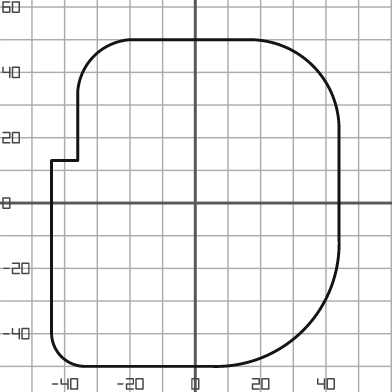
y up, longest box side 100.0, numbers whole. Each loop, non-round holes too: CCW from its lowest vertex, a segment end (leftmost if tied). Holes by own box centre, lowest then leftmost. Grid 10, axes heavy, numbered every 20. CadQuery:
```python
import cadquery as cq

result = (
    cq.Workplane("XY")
    .moveTo(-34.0, -50.0)
    .lineTo(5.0, -50.0)
    .threePointArc((33.0, -39.0), (44.0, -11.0))
    .lineTo(44.0, 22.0)
    .threePointArc((36.0, 42.0), (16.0, 50.0))
    .lineTo(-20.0, 50.0)
    .threePointArc((-31.0, 45.0), (-36.0, 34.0))
    .lineTo(-36.0, 13.0)
    .lineTo(-44.0, 13.0)
    .lineTo(-44.0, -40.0)
    .threePointArc((-41.0, -47.0), (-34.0, -50.0))
    .close()
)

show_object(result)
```